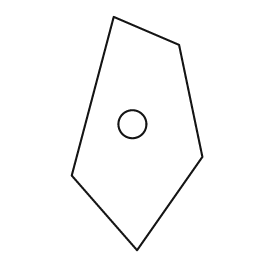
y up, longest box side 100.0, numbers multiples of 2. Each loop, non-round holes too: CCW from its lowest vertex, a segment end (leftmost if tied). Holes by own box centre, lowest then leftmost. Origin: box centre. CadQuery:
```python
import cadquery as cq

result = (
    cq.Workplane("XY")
    .moveTo(0.0, -50.0)
    .lineTo(28.0, -10.0)
    .lineTo(18.0, 38.0)
    .lineTo(-10.0, 50.0)
    .lineTo(-28.0, -18.0)
    .close()
    .moveTo(-2.0, 4.0)
    .circle(6.0)
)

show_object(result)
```